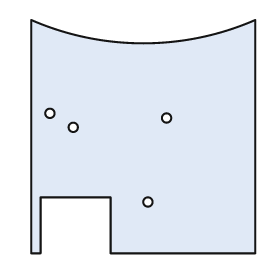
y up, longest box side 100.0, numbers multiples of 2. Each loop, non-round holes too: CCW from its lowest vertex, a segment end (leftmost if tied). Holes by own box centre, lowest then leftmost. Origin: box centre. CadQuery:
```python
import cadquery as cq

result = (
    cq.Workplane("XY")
    .moveTo(-48.0, -50.0)
    .lineTo(-44.0, -50.0)
    .lineTo(-44.0, -26.0)
    .lineTo(-14.0, -26.0)
    .lineTo(-14.0, -50.0)
    .lineTo(48.0, -50.0)
    .lineTo(48.0, 50.0)
    .threePointArc((0.0, 40.0), (-48.0, 50.0))
    .close()
    .moveTo(2.0, -28.0)
    .circle(2.0)
    .moveTo(-30.0, 4.0)
    .circle(2.0)
    .moveTo(10.0, 8.0)
    .circle(2.0)
    .moveTo(-40.0, 10.0)
    .circle(2.0)
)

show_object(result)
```